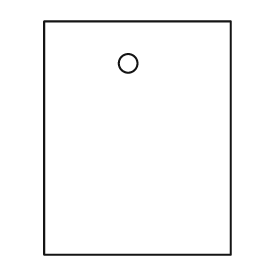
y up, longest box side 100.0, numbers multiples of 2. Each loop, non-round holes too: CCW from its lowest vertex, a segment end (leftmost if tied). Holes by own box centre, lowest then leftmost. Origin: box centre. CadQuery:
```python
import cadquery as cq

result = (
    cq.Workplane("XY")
    .moveTo(-40.0, -50.0)
    .lineTo(40.0, -50.0)
    .lineTo(40.0, 50.0)
    .lineTo(-40.0, 50.0)
    .close()
    .moveTo(-4.0, 32.0)
    .circle(4.0)
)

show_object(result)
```